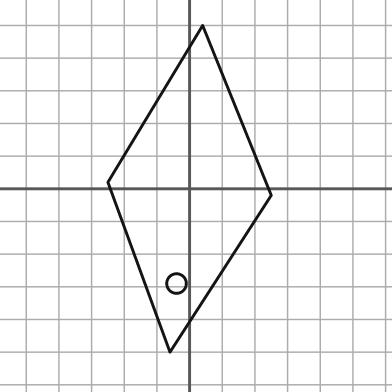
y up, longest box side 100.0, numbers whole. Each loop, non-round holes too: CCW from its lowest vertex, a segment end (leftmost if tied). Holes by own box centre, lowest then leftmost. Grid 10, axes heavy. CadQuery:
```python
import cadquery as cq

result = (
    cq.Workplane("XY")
    .moveTo(-6.0, -50.0)
    .lineTo(25.0, -2.0)
    .lineTo(4.0, 50.0)
    .lineTo(-25.0, 2.0)
    .close()
    .moveTo(-4.0, -29.0)
    .circle(3.0)
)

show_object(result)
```